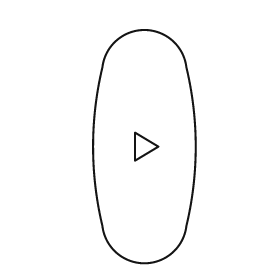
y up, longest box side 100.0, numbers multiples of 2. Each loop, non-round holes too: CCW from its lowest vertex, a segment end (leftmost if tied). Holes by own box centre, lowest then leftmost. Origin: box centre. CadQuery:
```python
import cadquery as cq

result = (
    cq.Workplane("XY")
    .moveTo(-18.0, -34.0)
    .threePointArc((0.0, -50.0), (18.0, -34.0))
    .threePointArc((22.0, 0.0), (18.0, 34.0))
    .threePointArc((0.0, 50.0), (-18.0, 34.0))
    .threePointArc((-22.0, 0.0), (-18.0, -34.0))
    .close()
    .moveTo(-4.0, -6.0)
    .lineTo(6.0, 0.0)
    .lineTo(-4.0, 6.0)
    .close()
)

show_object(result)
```